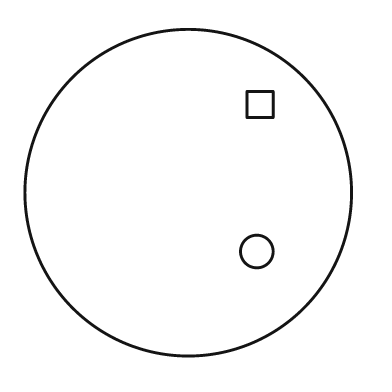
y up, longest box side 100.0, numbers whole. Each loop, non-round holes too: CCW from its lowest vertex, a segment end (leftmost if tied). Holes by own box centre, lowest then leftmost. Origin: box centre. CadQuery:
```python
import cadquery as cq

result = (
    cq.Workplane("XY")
    .moveTo(0.0, 0.0)
    .circle(50.0)
    .moveTo(21.0, -18.0)
    .circle(5.0)
    .moveTo(18.0, 23.0)
    .lineTo(26.0, 23.0)
    .lineTo(26.0, 31.0)
    .lineTo(18.0, 31.0)
    .close()
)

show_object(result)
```